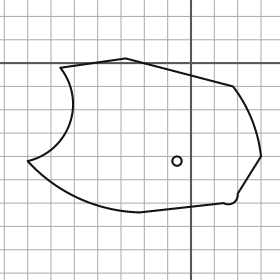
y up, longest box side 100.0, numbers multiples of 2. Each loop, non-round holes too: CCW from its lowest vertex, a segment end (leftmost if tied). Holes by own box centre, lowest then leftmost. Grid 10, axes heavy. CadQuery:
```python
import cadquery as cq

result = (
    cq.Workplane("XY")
    .moveTo(-22.0, -64.0)
    .lineTo(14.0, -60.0)
    .threePointArc((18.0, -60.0), (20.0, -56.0))
    .lineTo(30.0, -40.0)
    .threePointArc((26.0, -24.0), (18.0, -10.0))
    .lineTo(-28.0, 2.0)
    .lineTo(-56.0, -2.0)
    .threePointArc((-52.0, -26.0), (-70.0, -42.0))
    .threePointArc((-48.0, -58.0), (-22.0, -64.0))
    .close()
    .moveTo(-6.0, -42.0)
    .circle(2.0)
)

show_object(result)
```